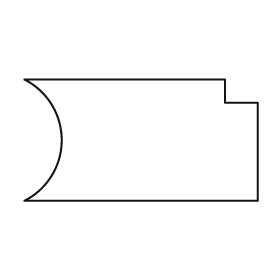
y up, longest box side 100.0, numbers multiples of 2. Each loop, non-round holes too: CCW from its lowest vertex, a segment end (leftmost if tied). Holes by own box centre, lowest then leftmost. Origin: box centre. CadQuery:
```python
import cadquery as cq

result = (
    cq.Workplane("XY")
    .moveTo(-50.0, -26.0)
    .lineTo(50.0, -26.0)
    .lineTo(50.0, 16.0)
    .lineTo(36.0, 16.0)
    .lineTo(36.0, 26.0)
    .lineTo(-50.0, 26.0)
    .threePointArc((-34.0, 0.0), (-50.0, -26.0))
    .close()
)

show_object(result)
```